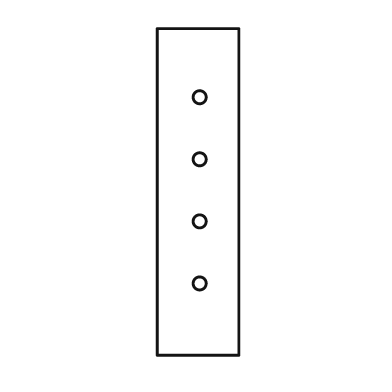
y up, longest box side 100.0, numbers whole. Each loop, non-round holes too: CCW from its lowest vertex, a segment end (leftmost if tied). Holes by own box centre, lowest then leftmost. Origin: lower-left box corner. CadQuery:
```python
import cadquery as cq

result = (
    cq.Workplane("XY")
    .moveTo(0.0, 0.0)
    .lineTo(25.0, 0.0)
    .lineTo(25.0, 100.0)
    .lineTo(0.0, 100.0)
    .close()
    .moveTo(13.0, 22.0)
    .circle(2.0)
    .moveTo(13.0, 41.0)
    .circle(2.0)
    .moveTo(13.0, 60.0)
    .circle(2.0)
    .moveTo(13.0, 79.0)
    .circle(2.0)
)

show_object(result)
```